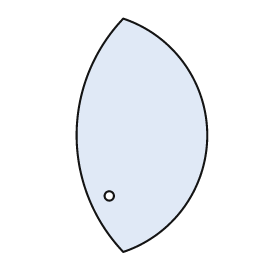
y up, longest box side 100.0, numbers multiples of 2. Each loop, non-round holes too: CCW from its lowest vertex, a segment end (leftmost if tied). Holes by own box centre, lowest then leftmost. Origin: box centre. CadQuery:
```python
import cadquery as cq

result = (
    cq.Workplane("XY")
    .moveTo(-8.0, -50.0)
    .threePointArc((28.0, 0.0), (-8.0, 50.0))
    .threePointArc((-28.0, 0.0), (-8.0, -50.0))
    .close()
    .moveTo(-14.0, -26.0)
    .circle(2.0)
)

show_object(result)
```